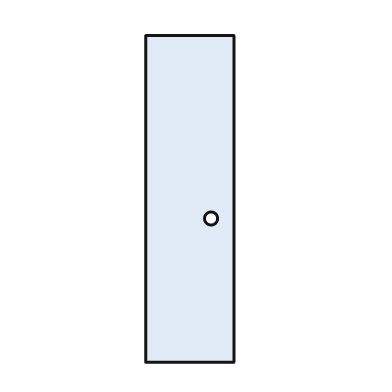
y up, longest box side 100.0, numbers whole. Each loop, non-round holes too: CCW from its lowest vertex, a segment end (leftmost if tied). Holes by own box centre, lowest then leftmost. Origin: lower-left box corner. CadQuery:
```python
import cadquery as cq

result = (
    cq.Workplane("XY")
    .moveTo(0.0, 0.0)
    .lineTo(27.0, 0.0)
    .lineTo(27.0, 100.0)
    .lineTo(0.0, 100.0)
    .close()
    .moveTo(20.0, 44.0)
    .circle(2.0)
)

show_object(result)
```